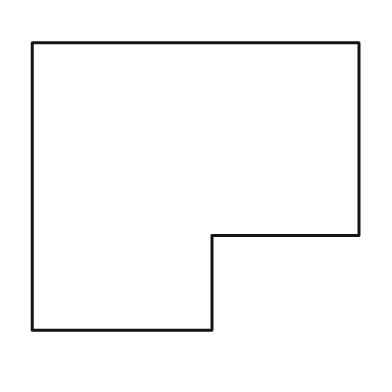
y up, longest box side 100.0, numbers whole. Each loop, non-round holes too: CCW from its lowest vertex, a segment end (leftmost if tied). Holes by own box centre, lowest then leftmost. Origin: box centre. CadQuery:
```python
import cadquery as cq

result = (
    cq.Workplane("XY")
    .moveTo(-50.0, -44.0)
    .lineTo(5.0, -44.0)
    .lineTo(5.0, -15.0)
    .lineTo(50.0, -15.0)
    .lineTo(50.0, 44.0)
    .lineTo(-50.0, 44.0)
    .close()
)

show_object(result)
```